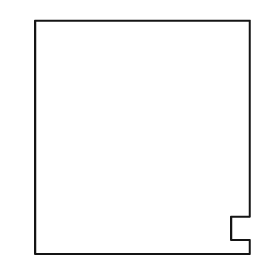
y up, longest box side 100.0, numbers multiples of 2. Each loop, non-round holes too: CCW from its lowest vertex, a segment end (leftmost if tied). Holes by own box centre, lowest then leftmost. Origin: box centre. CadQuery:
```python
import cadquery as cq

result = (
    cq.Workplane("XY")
    .moveTo(-46.0, -50.0)
    .lineTo(46.0, -50.0)
    .lineTo(46.0, -44.0)
    .lineTo(38.0, -44.0)
    .lineTo(38.0, -34.0)
    .lineTo(46.0, -34.0)
    .lineTo(46.0, 50.0)
    .lineTo(-46.0, 50.0)
    .close()
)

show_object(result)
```